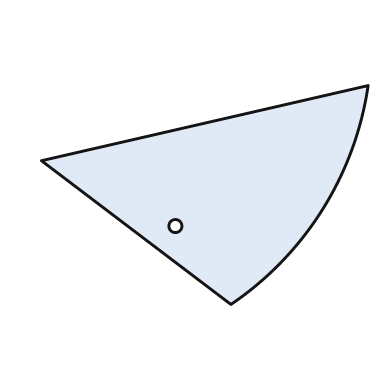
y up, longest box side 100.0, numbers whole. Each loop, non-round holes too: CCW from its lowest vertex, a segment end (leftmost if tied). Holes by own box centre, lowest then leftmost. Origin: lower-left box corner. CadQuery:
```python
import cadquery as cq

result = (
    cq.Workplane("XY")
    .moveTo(58.0, 0.0)
    .threePointArc((86.0, 29.0), (100.0, 67.0))
    .lineTo(0.0, 44.0)
    .close()
    .moveTo(41.0, 24.0)
    .circle(2.0)
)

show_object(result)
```